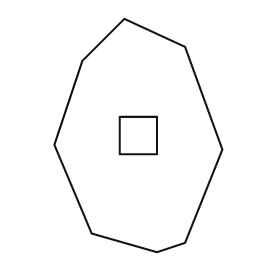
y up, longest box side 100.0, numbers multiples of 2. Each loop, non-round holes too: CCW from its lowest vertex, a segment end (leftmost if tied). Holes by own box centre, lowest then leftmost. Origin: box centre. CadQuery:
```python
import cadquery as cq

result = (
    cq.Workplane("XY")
    .moveTo(8.0, -50.0)
    .lineTo(20.0, -46.0)
    .lineTo(36.0, -6.0)
    .lineTo(20.0, 38.0)
    .lineTo(-6.0, 50.0)
    .lineTo(-24.0, 32.0)
    .lineTo(-36.0, -4.0)
    .lineTo(-20.0, -42.0)
    .close()
    .moveTo(-8.0, -8.0)
    .lineTo(8.0, -8.0)
    .lineTo(8.0, 8.0)
    .lineTo(-8.0, 8.0)
    .close()
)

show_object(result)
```